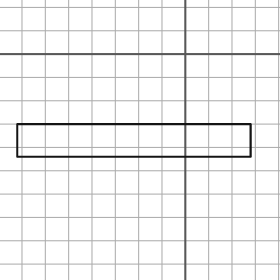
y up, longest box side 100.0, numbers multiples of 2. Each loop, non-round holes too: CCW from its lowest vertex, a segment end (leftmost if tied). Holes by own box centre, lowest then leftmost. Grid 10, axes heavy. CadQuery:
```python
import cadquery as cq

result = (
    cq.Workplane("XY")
    .moveTo(-72.0, -44.0)
    .lineTo(28.0, -44.0)
    .lineTo(28.0, -30.0)
    .lineTo(-72.0, -30.0)
    .close()
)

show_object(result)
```